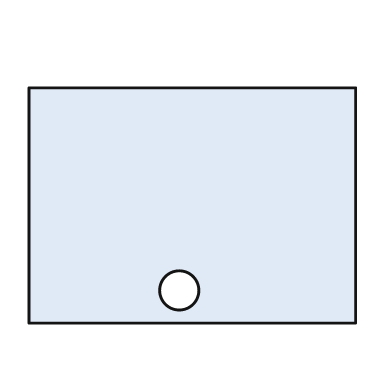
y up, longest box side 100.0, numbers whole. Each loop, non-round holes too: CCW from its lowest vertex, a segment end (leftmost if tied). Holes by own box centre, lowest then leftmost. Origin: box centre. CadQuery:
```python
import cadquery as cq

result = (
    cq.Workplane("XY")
    .moveTo(-50.0, -36.0)
    .lineTo(50.0, -36.0)
    .lineTo(50.0, 36.0)
    .lineTo(-50.0, 36.0)
    .close()
    .moveTo(-4.0, -26.0)
    .circle(6.0)
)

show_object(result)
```